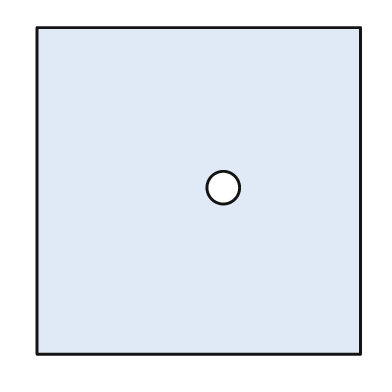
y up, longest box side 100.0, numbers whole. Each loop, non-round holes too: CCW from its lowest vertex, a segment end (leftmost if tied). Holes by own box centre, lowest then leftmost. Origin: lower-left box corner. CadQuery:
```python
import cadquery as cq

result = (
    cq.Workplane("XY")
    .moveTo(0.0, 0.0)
    .lineTo(99.0, 0.0)
    .lineTo(99.0, 100.0)
    .lineTo(0.0, 100.0)
    .close()
    .moveTo(57.0, 51.0)
    .circle(5.0)
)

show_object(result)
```